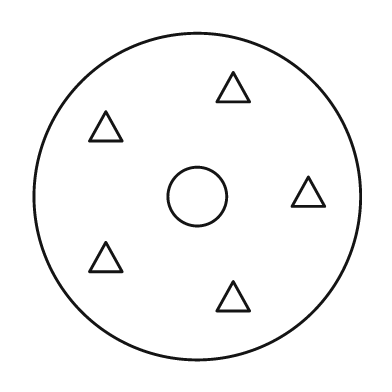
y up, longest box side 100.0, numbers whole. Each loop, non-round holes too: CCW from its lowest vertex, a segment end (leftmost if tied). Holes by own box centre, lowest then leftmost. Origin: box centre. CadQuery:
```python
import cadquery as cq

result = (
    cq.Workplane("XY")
    .moveTo(0.0, 0.0)
    .circle(50.0)
    .moveTo(6.0, -35.0)
    .lineTo(16.0, -35.0)
    .lineTo(11.0, -26.0)
    .close()
    .moveTo(-33.0, -23.0)
    .lineTo(-23.0, -23.0)
    .lineTo(-28.0, -14.0)
    .close()
    .moveTo(0.0, 0.0)
    .circle(9.0)
    .moveTo(29.0, -3.0)
    .lineTo(39.0, -3.0)
    .lineTo(34.0, 6.0)
    .close()
    .moveTo(-33.0, 17.0)
    .lineTo(-23.0, 17.0)
    .lineTo(-28.0, 26.0)
    .close()
    .moveTo(6.0, 29.0)
    .lineTo(16.0, 29.0)
    .lineTo(11.0, 38.0)
    .close()
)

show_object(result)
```